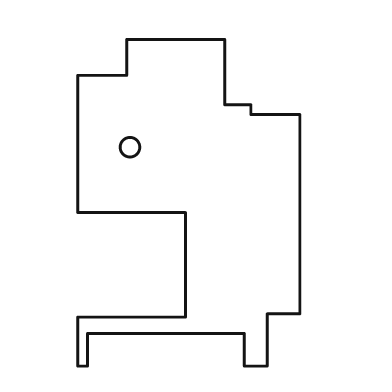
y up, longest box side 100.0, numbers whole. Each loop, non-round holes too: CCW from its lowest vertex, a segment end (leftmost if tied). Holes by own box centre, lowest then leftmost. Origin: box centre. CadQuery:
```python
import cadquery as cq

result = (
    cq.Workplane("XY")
    .moveTo(-34.0, -50.0)
    .lineTo(-31.0, -50.0)
    .lineTo(-31.0, -40.0)
    .lineTo(17.0, -40.0)
    .lineTo(17.0, -50.0)
    .lineTo(24.0, -50.0)
    .lineTo(24.0, -34.0)
    .lineTo(34.0, -34.0)
    .lineTo(34.0, 27.0)
    .lineTo(19.0, 27.0)
    .lineTo(19.0, 30.0)
    .lineTo(11.0, 30.0)
    .lineTo(11.0, 50.0)
    .lineTo(-19.0, 50.0)
    .lineTo(-19.0, 39.0)
    .lineTo(-34.0, 39.0)
    .lineTo(-34.0, -3.0)
    .lineTo(-1.0, -3.0)
    .lineTo(-1.0, -35.0)
    .lineTo(-34.0, -35.0)
    .close()
    .moveTo(-18.0, 17.0)
    .circle(3.0)
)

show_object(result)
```